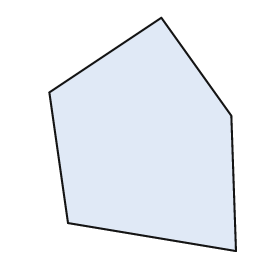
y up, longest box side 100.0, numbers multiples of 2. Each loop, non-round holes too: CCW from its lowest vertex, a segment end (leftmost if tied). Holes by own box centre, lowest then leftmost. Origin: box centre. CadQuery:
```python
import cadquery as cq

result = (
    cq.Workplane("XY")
    .moveTo(40.0, -50.0)
    .lineTo(38.0, 8.0)
    .lineTo(8.0, 50.0)
    .lineTo(-40.0, 18.0)
    .lineTo(-32.0, -38.0)
    .close()
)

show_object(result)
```